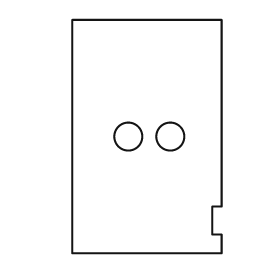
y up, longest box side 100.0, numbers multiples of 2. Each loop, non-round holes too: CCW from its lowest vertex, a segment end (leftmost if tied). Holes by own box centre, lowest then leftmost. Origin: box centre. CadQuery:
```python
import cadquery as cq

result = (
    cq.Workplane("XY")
    .moveTo(-32.0, -50.0)
    .lineTo(32.0, -50.0)
    .lineTo(32.0, -42.0)
    .lineTo(28.0, -42.0)
    .lineTo(28.0, -30.0)
    .lineTo(32.0, -30.0)
    .lineTo(32.0, 50.0)
    .lineTo(-32.0, 50.0)
    .close()
    .moveTo(-8.0, 0.0)
    .circle(6.0)
    .moveTo(10.0, 0.0)
    .circle(6.0)
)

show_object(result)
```